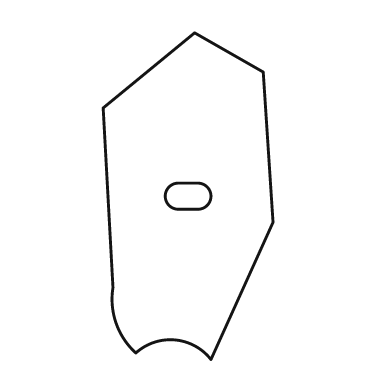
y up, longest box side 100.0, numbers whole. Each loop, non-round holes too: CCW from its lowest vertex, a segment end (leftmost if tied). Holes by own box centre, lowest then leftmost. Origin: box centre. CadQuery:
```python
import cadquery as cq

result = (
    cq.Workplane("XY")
    .moveTo(7.0, -50.0)
    .lineTo(26.0, -8.0)
    .lineTo(23.0, 38.0)
    .lineTo(2.0, 50.0)
    .lineTo(-26.0, 27.0)
    .lineTo(-23.0, -28.0)
    .threePointArc((-22.0, -39.0), (-16.0, -48.0))
    .threePointArc((-4.0, -44.0), (7.0, -50.0))
    .close()
    .moveTo(-3.0, -4.0)
    .lineTo(3.0, -4.0)
    .threePointArc((7.0, 0.0), (3.0, 4.0))
    .lineTo(-3.0, 4.0)
    .threePointArc((-7.0, 0.0), (-3.0, -4.0))
    .close()
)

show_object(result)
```